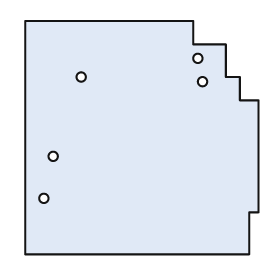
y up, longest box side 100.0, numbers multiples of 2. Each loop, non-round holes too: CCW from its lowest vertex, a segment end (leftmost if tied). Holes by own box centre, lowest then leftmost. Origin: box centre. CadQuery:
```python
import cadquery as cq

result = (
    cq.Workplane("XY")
    .moveTo(-50.0, -50.0)
    .lineTo(46.0, -50.0)
    .lineTo(46.0, -32.0)
    .lineTo(50.0, -32.0)
    .lineTo(50.0, 16.0)
    .lineTo(42.0, 16.0)
    .lineTo(42.0, 26.0)
    .lineTo(36.0, 26.0)
    .lineTo(36.0, 40.0)
    .lineTo(22.0, 40.0)
    .lineTo(22.0, 50.0)
    .lineTo(-50.0, 50.0)
    .close()
    .moveTo(-42.0, -26.0)
    .circle(2.0)
    .moveTo(-38.0, -8.0)
    .circle(2.0)
    .moveTo(26.0, 24.0)
    .circle(2.0)
    .moveTo(-26.0, 26.0)
    .circle(2.0)
    .moveTo(24.0, 34.0)
    .circle(2.0)
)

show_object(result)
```